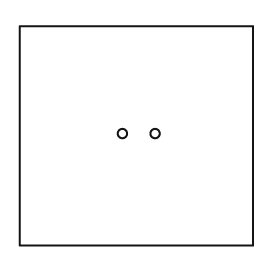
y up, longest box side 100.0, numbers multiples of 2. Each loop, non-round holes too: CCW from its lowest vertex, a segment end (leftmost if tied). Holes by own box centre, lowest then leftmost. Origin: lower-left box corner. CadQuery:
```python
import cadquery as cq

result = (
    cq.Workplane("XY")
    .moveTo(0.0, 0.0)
    .lineTo(100.0, 0.0)
    .lineTo(100.0, 94.0)
    .lineTo(0.0, 94.0)
    .close()
    .moveTo(44.0, 48.0)
    .circle(2.0)
    .moveTo(58.0, 48.0)
    .circle(2.0)
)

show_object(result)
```